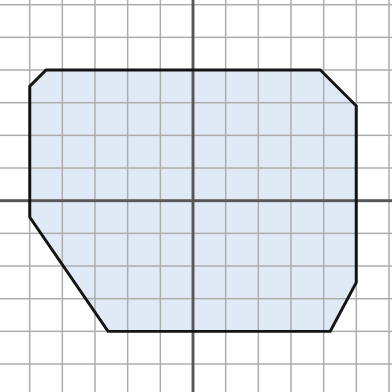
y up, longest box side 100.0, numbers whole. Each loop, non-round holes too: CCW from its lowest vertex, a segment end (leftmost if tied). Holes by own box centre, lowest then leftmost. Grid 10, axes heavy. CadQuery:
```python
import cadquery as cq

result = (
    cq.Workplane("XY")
    .moveTo(-26.0, -40.0)
    .lineTo(42.0, -40.0)
    .lineTo(50.0, -25.0)
    .lineTo(50.0, 29.0)
    .lineTo(39.0, 40.0)
    .lineTo(-45.0, 40.0)
    .lineTo(-50.0, 35.0)
    .lineTo(-50.0, -5.0)
    .close()
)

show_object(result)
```